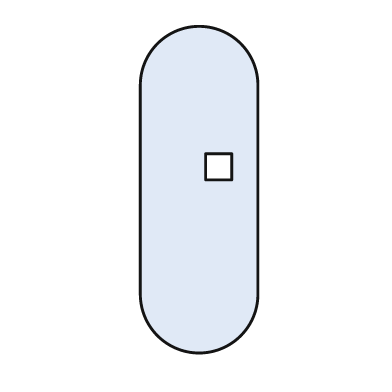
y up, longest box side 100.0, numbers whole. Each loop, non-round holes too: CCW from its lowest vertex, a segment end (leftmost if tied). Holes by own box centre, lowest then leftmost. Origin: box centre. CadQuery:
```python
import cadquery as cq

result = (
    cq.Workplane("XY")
    .moveTo(-18.0, -32.0)
    .threePointArc((0.0, -50.0), (18.0, -32.0))
    .lineTo(18.0, 32.0)
    .threePointArc((0.0, 50.0), (-18.0, 32.0))
    .close()
    .moveTo(2.0, 3.0)
    .lineTo(10.0, 3.0)
    .lineTo(10.0, 11.0)
    .lineTo(2.0, 11.0)
    .close()
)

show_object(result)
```